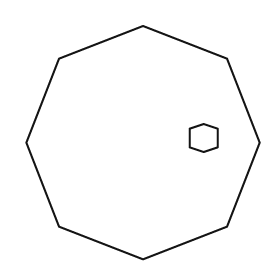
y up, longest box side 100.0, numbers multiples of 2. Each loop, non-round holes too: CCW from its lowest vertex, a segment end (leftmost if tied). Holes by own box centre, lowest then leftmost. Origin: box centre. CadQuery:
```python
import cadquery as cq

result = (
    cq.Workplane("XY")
    .moveTo(0.0, -50.0)
    .lineTo(36.0, -36.0)
    .lineTo(50.0, 0.0)
    .lineTo(36.0, 36.0)
    .lineTo(0.0, 50.0)
    .lineTo(-36.0, 36.0)
    .lineTo(-50.0, 0.0)
    .lineTo(-36.0, -36.0)
    .close()
    .moveTo(26.0, -4.0)
    .lineTo(32.0, -2.0)
    .lineTo(32.0, 6.0)
    .lineTo(26.0, 8.0)
    .lineTo(20.0, 6.0)
    .lineTo(20.0, -2.0)
    .close()
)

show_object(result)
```